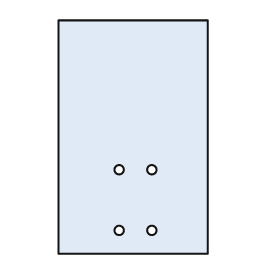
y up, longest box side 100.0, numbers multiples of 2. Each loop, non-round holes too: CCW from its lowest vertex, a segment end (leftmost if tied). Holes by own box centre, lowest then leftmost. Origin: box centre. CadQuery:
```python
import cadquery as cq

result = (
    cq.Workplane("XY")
    .moveTo(-32.0, -50.0)
    .lineTo(32.0, -50.0)
    .lineTo(32.0, 50.0)
    .lineTo(-32.0, 50.0)
    .close()
    .moveTo(-6.0, -40.0)
    .circle(2.0)
    .moveTo(8.0, -40.0)
    .circle(2.0)
    .moveTo(-6.0, -14.0)
    .circle(2.0)
    .moveTo(8.0, -14.0)
    .circle(2.0)
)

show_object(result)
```